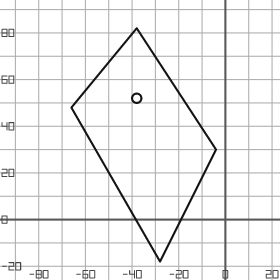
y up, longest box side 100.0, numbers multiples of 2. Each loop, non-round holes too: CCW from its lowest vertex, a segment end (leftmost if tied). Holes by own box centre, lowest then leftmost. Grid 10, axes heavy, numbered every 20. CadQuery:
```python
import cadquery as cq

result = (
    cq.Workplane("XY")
    .moveTo(-28.0, -18.0)
    .lineTo(-4.0, 30.0)
    .lineTo(-38.0, 82.0)
    .lineTo(-66.0, 48.0)
    .close()
    .moveTo(-38.0, 52.0)
    .circle(2.0)
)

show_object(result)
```